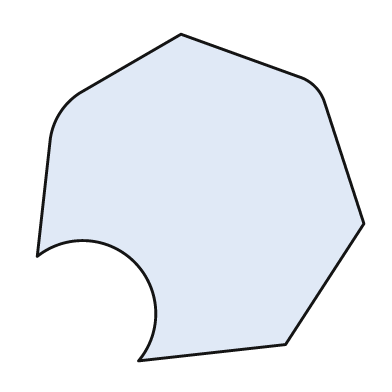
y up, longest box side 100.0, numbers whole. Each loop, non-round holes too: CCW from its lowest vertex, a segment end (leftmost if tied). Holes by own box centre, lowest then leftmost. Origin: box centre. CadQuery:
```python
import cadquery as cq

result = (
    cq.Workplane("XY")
    .moveTo(-19.0, -50.0)
    .lineTo(26.0, -45.0)
    .lineTo(50.0, -8.0)
    .lineTo(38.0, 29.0)
    .threePointArc((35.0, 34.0), (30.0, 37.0))
    .lineTo(-6.0, 50.0)
    .lineTo(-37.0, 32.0)
    .threePointArc((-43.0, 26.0), (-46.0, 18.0))
    .lineTo(-50.0, -18.0)
    .threePointArc((-20.0, -20.0), (-19.0, -50.0))
    .close()
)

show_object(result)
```